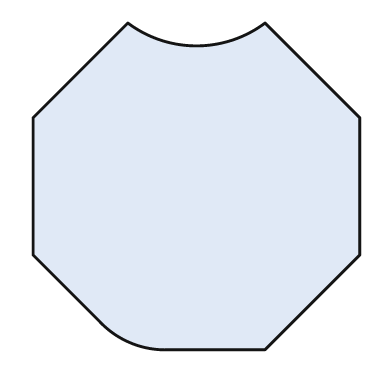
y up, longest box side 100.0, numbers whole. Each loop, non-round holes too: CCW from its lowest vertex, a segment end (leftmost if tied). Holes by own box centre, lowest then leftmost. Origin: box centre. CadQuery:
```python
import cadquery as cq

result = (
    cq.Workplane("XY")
    .moveTo(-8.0, -50.0)
    .lineTo(21.0, -50.0)
    .lineTo(50.0, -21.0)
    .lineTo(50.0, 21.0)
    .lineTo(21.0, 50.0)
    .threePointArc((0.0, 43.0), (-21.0, 50.0))
    .lineTo(-50.0, 21.0)
    .lineTo(-50.0, -21.0)
    .lineTo(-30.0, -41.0)
    .threePointArc((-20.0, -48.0), (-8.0, -50.0))
    .close()
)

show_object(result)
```